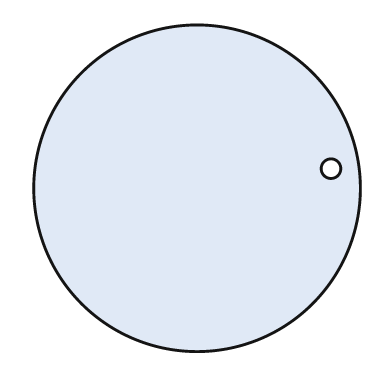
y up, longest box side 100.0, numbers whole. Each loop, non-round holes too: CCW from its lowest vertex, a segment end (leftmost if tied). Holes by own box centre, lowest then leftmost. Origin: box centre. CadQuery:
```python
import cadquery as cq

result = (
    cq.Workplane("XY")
    .moveTo(0.0, 0.0)
    .circle(50.0)
    .moveTo(41.0, 6.0)
    .circle(3.0)
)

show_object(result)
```